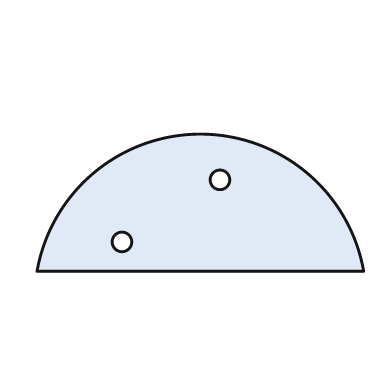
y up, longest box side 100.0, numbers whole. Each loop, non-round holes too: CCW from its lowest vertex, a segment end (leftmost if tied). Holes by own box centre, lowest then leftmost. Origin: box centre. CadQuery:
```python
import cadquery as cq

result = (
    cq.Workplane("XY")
    .moveTo(-50.0, -21.0)
    .lineTo(50.0, -21.0)
    .threePointArc((0.0, 21.0), (-50.0, -21.0))
    .close()
    .moveTo(-24.0, -12.0)
    .circle(3.0)
    .moveTo(6.0, 7.0)
    .circle(3.0)
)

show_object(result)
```